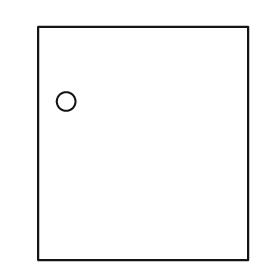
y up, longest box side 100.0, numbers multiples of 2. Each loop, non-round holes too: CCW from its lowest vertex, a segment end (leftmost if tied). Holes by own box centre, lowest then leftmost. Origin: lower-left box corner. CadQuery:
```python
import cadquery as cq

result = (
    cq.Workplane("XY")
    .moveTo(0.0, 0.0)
    .lineTo(90.0, 0.0)
    .lineTo(90.0, 100.0)
    .lineTo(0.0, 100.0)
    .close()
    .moveTo(12.0, 68.0)
    .circle(4.0)
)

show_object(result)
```